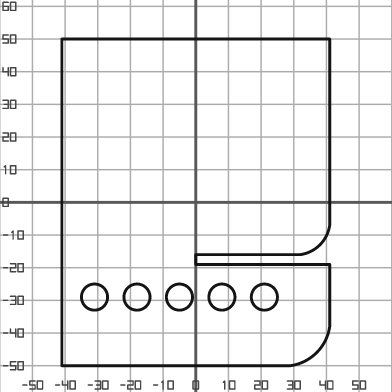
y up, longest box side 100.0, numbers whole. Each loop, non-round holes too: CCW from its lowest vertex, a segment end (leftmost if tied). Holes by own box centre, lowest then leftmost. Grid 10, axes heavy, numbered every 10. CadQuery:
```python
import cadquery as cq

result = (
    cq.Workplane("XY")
    .moveTo(-41.0, -50.0)
    .lineTo(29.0, -50.0)
    .threePointArc((37.0, -46.0), (41.0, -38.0))
    .lineTo(41.0, -19.0)
    .lineTo(0.0, -19.0)
    .lineTo(0.0, -16.0)
    .lineTo(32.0, -16.0)
    .threePointArc((38.0, -13.0), (41.0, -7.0))
    .lineTo(41.0, 50.0)
    .lineTo(-41.0, 50.0)
    .close()
    .moveTo(-31.0, -29.0)
    .circle(4.0)
    .moveTo(-18.0, -29.0)
    .circle(4.0)
    .moveTo(-5.0, -29.0)
    .circle(4.0)
    .moveTo(8.0, -29.0)
    .circle(4.0)
    .moveTo(21.0, -29.0)
    .circle(4.0)
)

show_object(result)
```